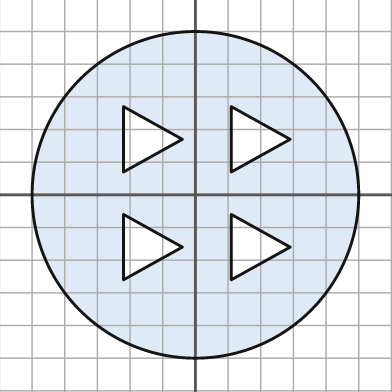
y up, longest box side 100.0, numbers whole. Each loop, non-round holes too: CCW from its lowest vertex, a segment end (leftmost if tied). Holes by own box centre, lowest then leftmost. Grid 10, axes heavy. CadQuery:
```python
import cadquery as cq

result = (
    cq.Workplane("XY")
    .moveTo(0.0, 0.0)
    .circle(50.0)
    .moveTo(-22.0, -26.0)
    .lineTo(-4.0, -16.0)
    .lineTo(-22.0, -6.0)
    .close()
    .moveTo(11.0, -26.0)
    .lineTo(29.0, -16.0)
    .lineTo(11.0, -6.0)
    .close()
    .moveTo(-22.0, 7.0)
    .lineTo(-4.0, 17.0)
    .lineTo(-22.0, 27.0)
    .close()
    .moveTo(11.0, 7.0)
    .lineTo(29.0, 17.0)
    .lineTo(11.0, 27.0)
    .close()
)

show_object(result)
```